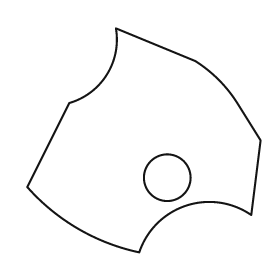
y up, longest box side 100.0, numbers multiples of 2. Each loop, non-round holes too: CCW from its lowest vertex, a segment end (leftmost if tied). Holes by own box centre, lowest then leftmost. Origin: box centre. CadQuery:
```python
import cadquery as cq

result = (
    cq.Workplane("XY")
    .moveTo(-2.0, -48.0)
    .threePointArc((18.0, -28.0), (46.0, -32.0))
    .lineTo(50.0, 0.0)
    .lineTo(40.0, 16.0)
    .threePointArc((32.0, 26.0), (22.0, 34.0))
    .lineTo(-12.0, 48.0)
    .threePointArc((-16.0, 28.0), (-32.0, 16.0))
    .lineTo(-50.0, -20.0)
    .threePointArc((-28.0, -38.0), (-2.0, -48.0))
    .close()
    .moveTo(10.0, -16.0)
    .circle(10.0)
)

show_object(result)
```